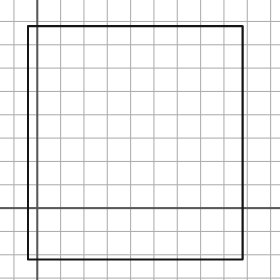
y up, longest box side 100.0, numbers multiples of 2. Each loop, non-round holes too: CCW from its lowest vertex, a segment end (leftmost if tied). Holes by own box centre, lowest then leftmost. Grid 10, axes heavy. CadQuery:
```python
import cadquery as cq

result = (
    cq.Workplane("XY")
    .moveTo(-4.0, -22.0)
    .lineTo(88.0, -22.0)
    .lineTo(88.0, 78.0)
    .lineTo(-4.0, 78.0)
    .close()
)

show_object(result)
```